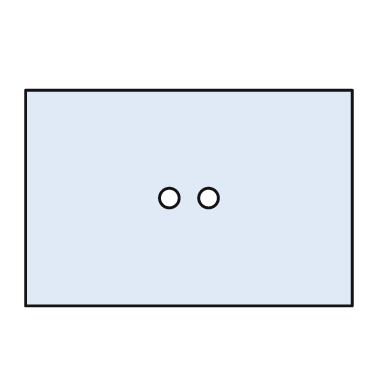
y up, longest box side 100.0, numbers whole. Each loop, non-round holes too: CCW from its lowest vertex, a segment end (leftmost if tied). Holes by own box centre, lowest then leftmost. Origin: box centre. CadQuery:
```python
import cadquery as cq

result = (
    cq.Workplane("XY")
    .moveTo(-50.0, -33.0)
    .lineTo(50.0, -33.0)
    .lineTo(50.0, 33.0)
    .lineTo(-50.0, 33.0)
    .close()
    .moveTo(-6.0, 0.0)
    .circle(3.0)
    .moveTo(6.0, 0.0)
    .circle(3.0)
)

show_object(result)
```